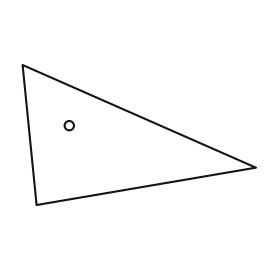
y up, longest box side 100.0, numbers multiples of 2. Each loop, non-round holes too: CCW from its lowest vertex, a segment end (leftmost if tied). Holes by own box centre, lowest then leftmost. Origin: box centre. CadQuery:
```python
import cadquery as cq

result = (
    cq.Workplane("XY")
    .moveTo(-44.0, -30.0)
    .lineTo(50.0, -14.0)
    .lineTo(-50.0, 30.0)
    .close()
    .moveTo(-30.0, 4.0)
    .circle(2.0)
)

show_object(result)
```